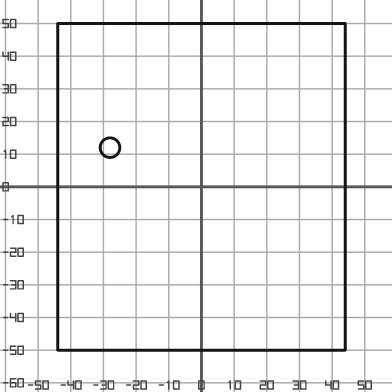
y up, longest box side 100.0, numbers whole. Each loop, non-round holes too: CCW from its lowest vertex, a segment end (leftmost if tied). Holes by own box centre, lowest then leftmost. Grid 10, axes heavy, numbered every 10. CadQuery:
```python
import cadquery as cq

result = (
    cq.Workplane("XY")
    .moveTo(-44.0, -50.0)
    .lineTo(44.0, -50.0)
    .lineTo(44.0, 50.0)
    .lineTo(-44.0, 50.0)
    .close()
    .moveTo(-28.0, 12.0)
    .circle(3.0)
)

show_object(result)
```